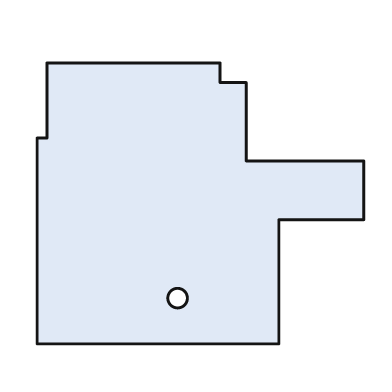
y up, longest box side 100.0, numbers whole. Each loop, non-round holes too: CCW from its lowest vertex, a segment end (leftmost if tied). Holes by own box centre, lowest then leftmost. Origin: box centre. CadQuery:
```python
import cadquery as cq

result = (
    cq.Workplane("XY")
    .moveTo(-50.0, -43.0)
    .lineTo(24.0, -43.0)
    .lineTo(24.0, -5.0)
    .lineTo(50.0, -5.0)
    .lineTo(50.0, 13.0)
    .lineTo(14.0, 13.0)
    .lineTo(14.0, 37.0)
    .lineTo(6.0, 37.0)
    .lineTo(6.0, 43.0)
    .lineTo(-47.0, 43.0)
    .lineTo(-47.0, 20.0)
    .lineTo(-50.0, 20.0)
    .close()
    .moveTo(-7.0, -29.0)
    .circle(3.0)
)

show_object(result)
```